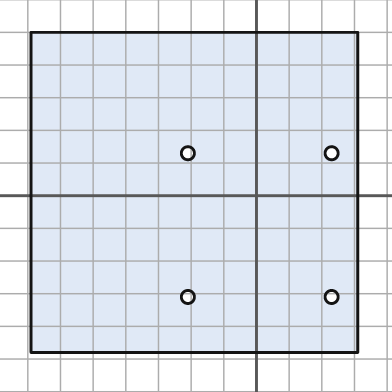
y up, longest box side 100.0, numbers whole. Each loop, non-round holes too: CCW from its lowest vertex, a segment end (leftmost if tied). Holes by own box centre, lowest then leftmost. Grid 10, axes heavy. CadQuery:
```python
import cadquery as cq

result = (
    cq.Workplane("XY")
    .moveTo(-69.0, -48.0)
    .lineTo(31.0, -48.0)
    .lineTo(31.0, 50.0)
    .lineTo(-69.0, 50.0)
    .close()
    .moveTo(-21.0, -31.0)
    .circle(2.0)
    .moveTo(23.0, -31.0)
    .circle(2.0)
    .moveTo(-21.0, 13.0)
    .circle(2.0)
    .moveTo(23.0, 13.0)
    .circle(2.0)
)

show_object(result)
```